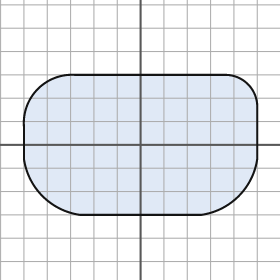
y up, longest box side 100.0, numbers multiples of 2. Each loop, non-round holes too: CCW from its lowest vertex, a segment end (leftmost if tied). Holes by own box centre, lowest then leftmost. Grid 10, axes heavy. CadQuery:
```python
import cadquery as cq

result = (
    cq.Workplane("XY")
    .moveTo(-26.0, -30.0)
    .lineTo(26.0, -30.0)
    .threePointArc((42.0, -22.0), (50.0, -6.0))
    .lineTo(50.0, 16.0)
    .threePointArc((46.0, 26.0), (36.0, 30.0))
    .lineTo(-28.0, 30.0)
    .threePointArc((-44.0, 24.0), (-50.0, 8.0))
    .lineTo(-50.0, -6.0)
    .threePointArc((-42.0, -22.0), (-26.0, -30.0))
    .close()
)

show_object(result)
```